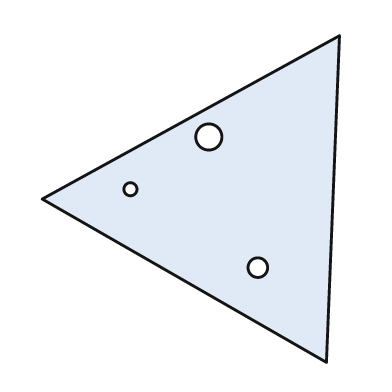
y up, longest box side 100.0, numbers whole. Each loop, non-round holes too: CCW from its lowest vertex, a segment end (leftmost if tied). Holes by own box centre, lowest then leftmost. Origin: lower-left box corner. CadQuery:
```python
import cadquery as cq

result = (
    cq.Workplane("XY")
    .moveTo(87.0, 0.0)
    .lineTo(91.0, 100.0)
    .lineTo(0.0, 50.0)
    .close()
    .moveTo(66.0, 29.0)
    .circle(3.0)
    .moveTo(27.0, 53.0)
    .circle(2.0)
    .moveTo(51.0, 69.0)
    .circle(4.0)
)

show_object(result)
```